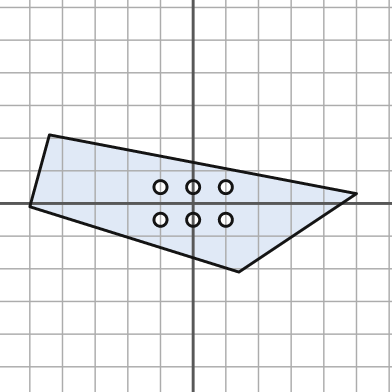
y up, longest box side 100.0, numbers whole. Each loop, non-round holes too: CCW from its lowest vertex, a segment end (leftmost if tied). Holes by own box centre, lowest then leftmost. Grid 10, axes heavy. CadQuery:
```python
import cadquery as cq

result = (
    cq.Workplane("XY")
    .moveTo(14.0, -21.0)
    .lineTo(50.0, 3.0)
    .lineTo(-44.0, 21.0)
    .lineTo(-50.0, -1.0)
    .close()
    .moveTo(-10.0, -5.0)
    .circle(2.0)
    .moveTo(0.0, -5.0)
    .circle(2.0)
    .moveTo(10.0, -5.0)
    .circle(2.0)
    .moveTo(-10.0, 5.0)
    .circle(2.0)
    .moveTo(0.0, 5.0)
    .circle(2.0)
    .moveTo(10.0, 5.0)
    .circle(2.0)
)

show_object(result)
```